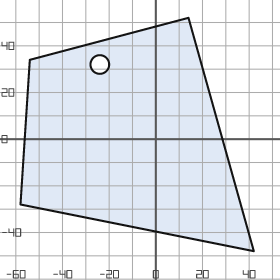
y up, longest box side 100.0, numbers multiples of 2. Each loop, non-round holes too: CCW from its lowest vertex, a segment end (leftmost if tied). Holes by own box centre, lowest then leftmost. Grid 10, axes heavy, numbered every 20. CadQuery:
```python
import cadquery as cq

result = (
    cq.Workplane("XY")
    .moveTo(42.0, -48.0)
    .lineTo(14.0, 52.0)
    .lineTo(-54.0, 34.0)
    .lineTo(-58.0, -28.0)
    .close()
    .moveTo(-24.0, 32.0)
    .circle(4.0)
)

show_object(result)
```